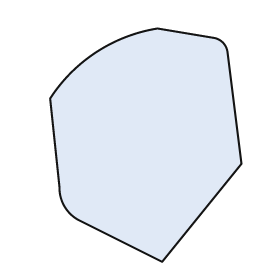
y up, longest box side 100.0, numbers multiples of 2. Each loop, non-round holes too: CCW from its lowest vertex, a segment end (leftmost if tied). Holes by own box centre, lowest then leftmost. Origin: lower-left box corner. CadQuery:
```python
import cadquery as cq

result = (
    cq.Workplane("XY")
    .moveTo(48.0, 0.0)
    .lineTo(82.0, 42.0)
    .lineTo(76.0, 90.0)
    .threePointArc((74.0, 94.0), (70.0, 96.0))
    .lineTo(46.0, 100.0)
    .threePointArc((20.0, 90.0), (0.0, 70.0))
    .lineTo(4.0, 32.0)
    .threePointArc((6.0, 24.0), (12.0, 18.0))
    .close()
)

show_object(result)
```